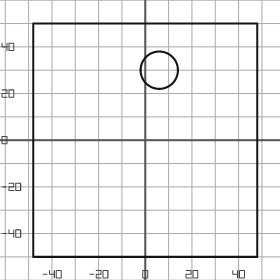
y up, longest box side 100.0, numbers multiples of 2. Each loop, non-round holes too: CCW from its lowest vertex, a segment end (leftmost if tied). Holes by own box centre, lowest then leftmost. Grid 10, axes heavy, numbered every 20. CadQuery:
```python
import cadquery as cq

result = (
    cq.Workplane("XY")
    .moveTo(-48.0, -50.0)
    .lineTo(48.0, -50.0)
    .lineTo(48.0, 50.0)
    .lineTo(-48.0, 50.0)
    .close()
    .moveTo(6.0, 30.0)
    .circle(8.0)
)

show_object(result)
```